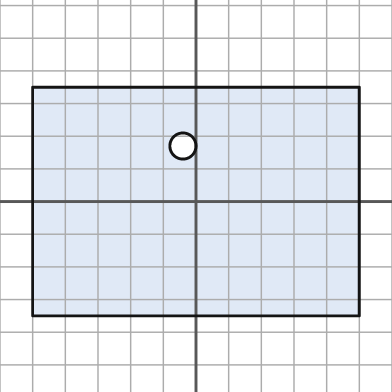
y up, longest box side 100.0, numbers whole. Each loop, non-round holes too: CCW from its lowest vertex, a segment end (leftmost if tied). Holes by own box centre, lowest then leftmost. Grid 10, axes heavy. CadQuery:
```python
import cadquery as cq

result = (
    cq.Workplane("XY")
    .moveTo(-50.0, -35.0)
    .lineTo(50.0, -35.0)
    .lineTo(50.0, 35.0)
    .lineTo(-50.0, 35.0)
    .close()
    .moveTo(-4.0, 17.0)
    .circle(4.0)
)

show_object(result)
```